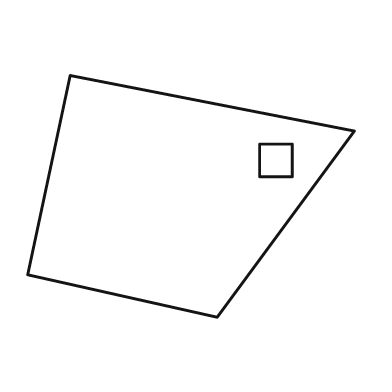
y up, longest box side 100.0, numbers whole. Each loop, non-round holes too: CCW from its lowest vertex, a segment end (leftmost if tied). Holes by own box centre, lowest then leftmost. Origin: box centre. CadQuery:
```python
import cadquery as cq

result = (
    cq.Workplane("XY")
    .moveTo(8.0, -37.0)
    .lineTo(50.0, 20.0)
    .lineTo(-37.0, 37.0)
    .lineTo(-50.0, -24.0)
    .close()
    .moveTo(21.0, 6.0)
    .lineTo(31.0, 6.0)
    .lineTo(31.0, 16.0)
    .lineTo(21.0, 16.0)
    .close()
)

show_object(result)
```